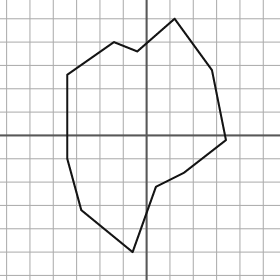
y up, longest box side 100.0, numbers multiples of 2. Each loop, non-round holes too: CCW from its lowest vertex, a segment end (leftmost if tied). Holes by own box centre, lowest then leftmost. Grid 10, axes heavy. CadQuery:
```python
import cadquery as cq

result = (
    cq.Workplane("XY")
    .moveTo(-6.0, -50.0)
    .lineTo(4.0, -22.0)
    .lineTo(16.0, -16.0)
    .lineTo(34.0, -2.0)
    .lineTo(28.0, 28.0)
    .lineTo(12.0, 50.0)
    .lineTo(-4.0, 36.0)
    .lineTo(-14.0, 40.0)
    .lineTo(-34.0, 26.0)
    .lineTo(-34.0, -10.0)
    .lineTo(-28.0, -32.0)
    .close()
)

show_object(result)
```